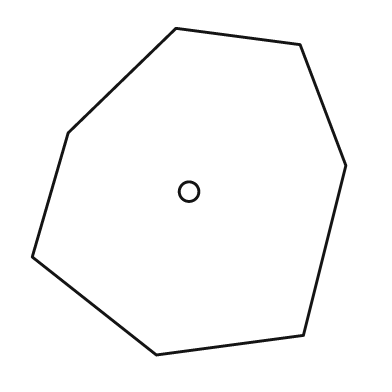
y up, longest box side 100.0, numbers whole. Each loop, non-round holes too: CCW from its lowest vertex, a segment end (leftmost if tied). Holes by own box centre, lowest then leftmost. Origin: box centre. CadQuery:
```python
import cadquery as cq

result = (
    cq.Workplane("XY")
    .moveTo(-10.0, -50.0)
    .lineTo(35.0, -44.0)
    .lineTo(48.0, 8.0)
    .lineTo(34.0, 45.0)
    .lineTo(-4.0, 50.0)
    .lineTo(-37.0, 18.0)
    .lineTo(-48.0, -20.0)
    .close()
    .moveTo(0.0, 0.0)
    .circle(3.0)
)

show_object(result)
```